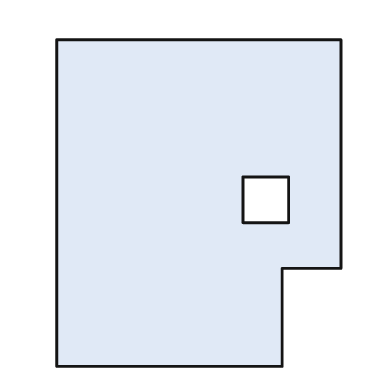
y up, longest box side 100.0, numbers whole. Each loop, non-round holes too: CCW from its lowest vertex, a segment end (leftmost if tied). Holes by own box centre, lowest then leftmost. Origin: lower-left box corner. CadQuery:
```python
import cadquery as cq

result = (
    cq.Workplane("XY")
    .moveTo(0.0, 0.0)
    .lineTo(69.0, 0.0)
    .lineTo(69.0, 30.0)
    .lineTo(87.0, 30.0)
    .lineTo(87.0, 100.0)
    .lineTo(0.0, 100.0)
    .close()
    .moveTo(57.0, 44.0)
    .lineTo(71.0, 44.0)
    .lineTo(71.0, 58.0)
    .lineTo(57.0, 58.0)
    .close()
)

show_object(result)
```